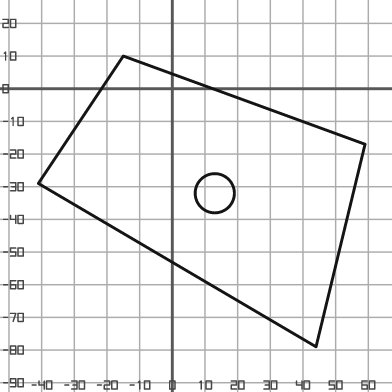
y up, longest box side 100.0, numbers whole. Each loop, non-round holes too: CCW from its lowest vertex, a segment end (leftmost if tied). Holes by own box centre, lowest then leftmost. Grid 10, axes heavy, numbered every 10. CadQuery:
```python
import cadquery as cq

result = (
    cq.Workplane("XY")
    .moveTo(44.0, -79.0)
    .lineTo(59.0, -17.0)
    .lineTo(-15.0, 10.0)
    .lineTo(-41.0, -29.0)
    .close()
    .moveTo(13.0, -32.0)
    .circle(6.0)
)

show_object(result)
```